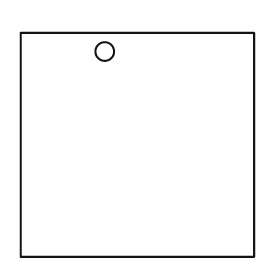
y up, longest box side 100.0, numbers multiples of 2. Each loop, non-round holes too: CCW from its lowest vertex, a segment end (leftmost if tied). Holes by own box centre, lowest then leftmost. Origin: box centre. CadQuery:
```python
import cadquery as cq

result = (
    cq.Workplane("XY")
    .moveTo(-50.0, -48.0)
    .lineTo(50.0, -48.0)
    .lineTo(50.0, 48.0)
    .lineTo(-50.0, 48.0)
    .close()
    .moveTo(-14.0, 40.0)
    .circle(4.0)
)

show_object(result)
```